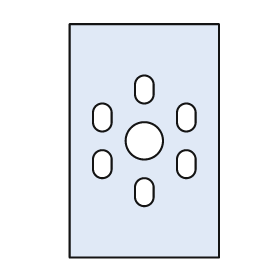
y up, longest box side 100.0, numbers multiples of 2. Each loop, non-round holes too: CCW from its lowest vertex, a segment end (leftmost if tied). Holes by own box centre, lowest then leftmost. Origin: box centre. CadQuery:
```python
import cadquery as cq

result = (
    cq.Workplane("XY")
    .moveTo(-32.0, -50.0)
    .lineTo(32.0, -50.0)
    .lineTo(32.0, 50.0)
    .lineTo(-32.0, 50.0)
    .close()
    .moveTo(-4.0, -24.0)
    .threePointArc((0.0, -28.0), (4.0, -24.0))
    .lineTo(4.0, -20.0)
    .threePointArc((0.0, -16.0), (-4.0, -20.0))
    .close()
    .moveTo(-22.0, -12.0)
    .threePointArc((-18.0, -16.0), (-14.0, -12.0))
    .lineTo(-14.0, -8.0)
    .threePointArc((-18.0, -4.0), (-22.0, -8.0))
    .close()
    .moveTo(14.0, -12.0)
    .threePointArc((18.0, -16.0), (22.0, -12.0))
    .lineTo(22.0, -8.0)
    .threePointArc((18.0, -4.0), (14.0, -8.0))
    .close()
    .moveTo(0.0, 0.0)
    .circle(8.0)
    .moveTo(-22.0, 8.0)
    .threePointArc((-18.0, 4.0), (-14.0, 8.0))
    .lineTo(-14.0, 12.0)
    .threePointArc((-18.0, 16.0), (-22.0, 12.0))
    .close()
    .moveTo(14.0, 8.0)
    .threePointArc((18.0, 4.0), (22.0, 8.0))
    .lineTo(22.0, 12.0)
    .threePointArc((18.0, 16.0), (14.0, 12.0))
    .close()
    .moveTo(-4.0, 20.0)
    .threePointArc((0.0, 16.0), (4.0, 20.0))
    .lineTo(4.0, 24.0)
    .threePointArc((0.0, 28.0), (-4.0, 24.0))
    .close()
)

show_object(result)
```